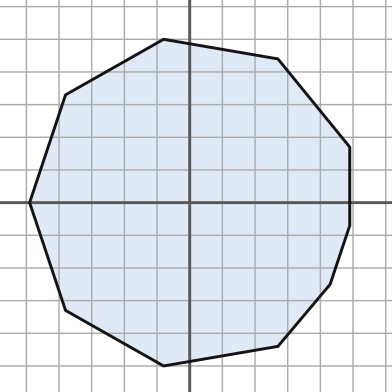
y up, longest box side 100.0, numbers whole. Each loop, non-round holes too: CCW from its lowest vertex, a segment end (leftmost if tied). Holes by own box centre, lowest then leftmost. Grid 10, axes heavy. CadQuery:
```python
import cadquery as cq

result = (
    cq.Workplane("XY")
    .moveTo(-8.0, -50.0)
    .lineTo(27.0, -44.0)
    .lineTo(43.0, -25.0)
    .lineTo(49.0, -7.0)
    .lineTo(49.0, 17.0)
    .lineTo(27.0, 44.0)
    .lineTo(-8.0, 50.0)
    .lineTo(-38.0, 33.0)
    .lineTo(-49.0, 0.0)
    .lineTo(-38.0, -33.0)
    .close()
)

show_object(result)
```